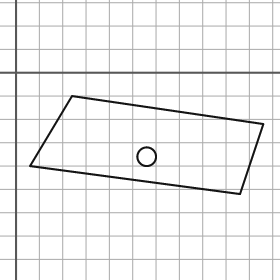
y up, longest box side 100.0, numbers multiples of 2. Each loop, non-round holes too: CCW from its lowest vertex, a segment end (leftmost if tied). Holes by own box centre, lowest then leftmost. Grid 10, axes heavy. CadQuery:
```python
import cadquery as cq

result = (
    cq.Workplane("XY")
    .moveTo(96.0, -52.0)
    .lineTo(106.0, -22.0)
    .lineTo(24.0, -10.0)
    .lineTo(6.0, -40.0)
    .close()
    .moveTo(56.0, -36.0)
    .circle(4.0)
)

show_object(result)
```